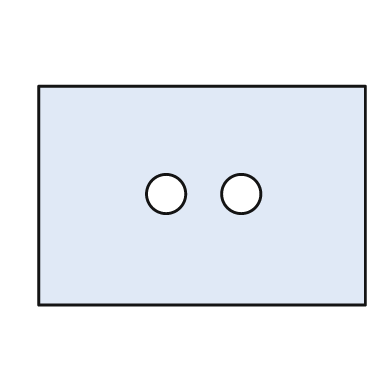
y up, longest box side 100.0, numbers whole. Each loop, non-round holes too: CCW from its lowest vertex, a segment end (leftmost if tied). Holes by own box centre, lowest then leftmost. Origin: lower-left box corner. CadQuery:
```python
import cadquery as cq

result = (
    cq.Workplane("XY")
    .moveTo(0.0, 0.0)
    .lineTo(100.0, 0.0)
    .lineTo(100.0, 67.0)
    .lineTo(0.0, 67.0)
    .close()
    .moveTo(39.0, 34.0)
    .circle(6.0)
    .moveTo(62.0, 34.0)
    .circle(6.0)
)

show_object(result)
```